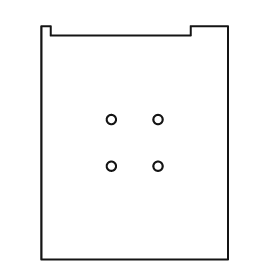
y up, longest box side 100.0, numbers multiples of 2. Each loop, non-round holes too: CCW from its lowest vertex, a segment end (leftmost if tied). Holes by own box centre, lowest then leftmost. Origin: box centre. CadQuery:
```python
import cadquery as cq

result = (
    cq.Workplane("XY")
    .moveTo(-40.0, -50.0)
    .lineTo(40.0, -50.0)
    .lineTo(40.0, 50.0)
    .lineTo(24.0, 50.0)
    .lineTo(24.0, 46.0)
    .lineTo(-36.0, 46.0)
    .lineTo(-36.0, 50.0)
    .lineTo(-40.0, 50.0)
    .close()
    .moveTo(-10.0, -10.0)
    .circle(2.0)
    .moveTo(10.0, -10.0)
    .circle(2.0)
    .moveTo(-10.0, 10.0)
    .circle(2.0)
    .moveTo(10.0, 10.0)
    .circle(2.0)
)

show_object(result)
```